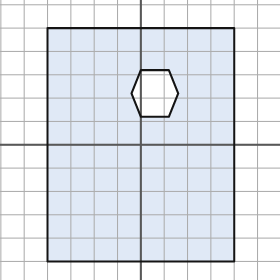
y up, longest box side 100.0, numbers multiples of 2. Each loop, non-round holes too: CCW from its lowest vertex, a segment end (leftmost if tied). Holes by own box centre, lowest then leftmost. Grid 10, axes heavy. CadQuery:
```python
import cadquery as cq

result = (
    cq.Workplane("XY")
    .moveTo(-40.0, -50.0)
    .lineTo(40.0, -50.0)
    .lineTo(40.0, 50.0)
    .lineTo(-40.0, 50.0)
    .close()
    .moveTo(0.0, 12.0)
    .lineTo(12.0, 12.0)
    .lineTo(16.0, 22.0)
    .lineTo(12.0, 32.0)
    .lineTo(0.0, 32.0)
    .lineTo(-4.0, 22.0)
    .close()
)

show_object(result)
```